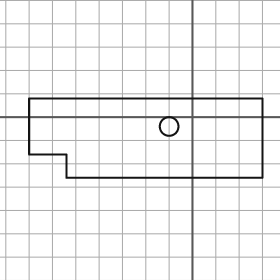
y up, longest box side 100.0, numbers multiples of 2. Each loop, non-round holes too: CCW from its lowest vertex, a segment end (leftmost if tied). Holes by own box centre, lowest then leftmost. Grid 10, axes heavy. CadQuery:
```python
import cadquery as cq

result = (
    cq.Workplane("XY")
    .moveTo(-54.0, -26.0)
    .lineTo(30.0, -26.0)
    .lineTo(30.0, 8.0)
    .lineTo(-70.0, 8.0)
    .lineTo(-70.0, -16.0)
    .lineTo(-54.0, -16.0)
    .close()
    .moveTo(-10.0, -4.0)
    .circle(4.0)
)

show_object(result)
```